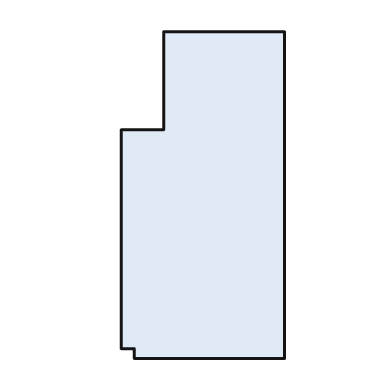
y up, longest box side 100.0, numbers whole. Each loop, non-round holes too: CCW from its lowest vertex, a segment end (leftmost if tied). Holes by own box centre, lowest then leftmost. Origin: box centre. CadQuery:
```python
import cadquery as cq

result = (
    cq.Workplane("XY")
    .moveTo(-21.0, -50.0)
    .lineTo(25.0, -50.0)
    .lineTo(25.0, 50.0)
    .lineTo(-12.0, 50.0)
    .lineTo(-12.0, 20.0)
    .lineTo(-25.0, 20.0)
    .lineTo(-25.0, -47.0)
    .lineTo(-21.0, -47.0)
    .close()
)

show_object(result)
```